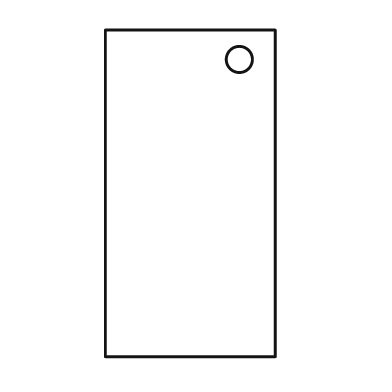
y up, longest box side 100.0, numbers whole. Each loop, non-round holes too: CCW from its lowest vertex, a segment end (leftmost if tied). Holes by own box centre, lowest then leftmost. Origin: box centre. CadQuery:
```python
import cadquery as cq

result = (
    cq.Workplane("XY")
    .moveTo(-26.0, -50.0)
    .lineTo(26.0, -50.0)
    .lineTo(26.0, 50.0)
    .lineTo(-26.0, 50.0)
    .close()
    .moveTo(15.0, 41.0)
    .circle(4.0)
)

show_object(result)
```